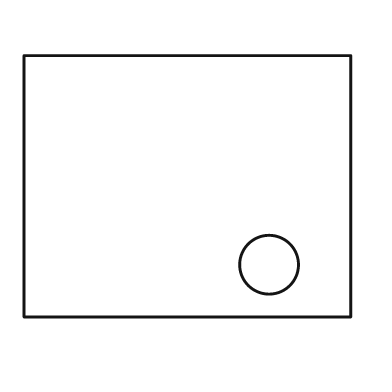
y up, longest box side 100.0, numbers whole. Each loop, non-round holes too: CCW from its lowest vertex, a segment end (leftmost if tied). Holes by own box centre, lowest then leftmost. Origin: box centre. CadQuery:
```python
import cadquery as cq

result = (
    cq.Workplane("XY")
    .moveTo(-50.0, -40.0)
    .lineTo(50.0, -40.0)
    .lineTo(50.0, 40.0)
    .lineTo(-50.0, 40.0)
    .close()
    .moveTo(25.0, -24.0)
    .circle(9.0)
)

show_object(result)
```